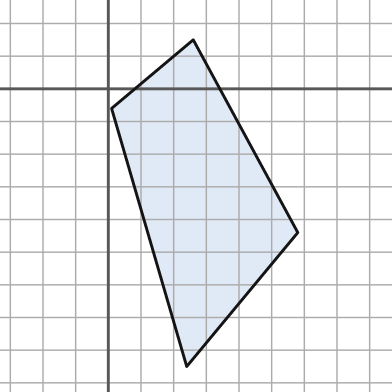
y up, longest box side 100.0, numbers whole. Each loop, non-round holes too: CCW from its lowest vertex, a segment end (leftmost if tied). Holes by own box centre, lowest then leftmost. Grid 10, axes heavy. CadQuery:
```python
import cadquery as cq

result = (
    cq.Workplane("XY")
    .moveTo(24.0, -85.0)
    .lineTo(58.0, -44.0)
    .lineTo(26.0, 15.0)
    .lineTo(1.0, -6.0)
    .close()
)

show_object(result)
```